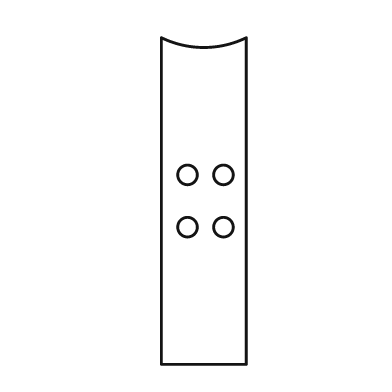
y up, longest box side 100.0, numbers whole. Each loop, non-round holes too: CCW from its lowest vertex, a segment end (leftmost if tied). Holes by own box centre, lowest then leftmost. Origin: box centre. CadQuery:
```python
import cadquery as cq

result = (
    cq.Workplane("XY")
    .moveTo(-13.0, -50.0)
    .lineTo(13.0, -50.0)
    .lineTo(13.0, 50.0)
    .threePointArc((0.0, 47.0), (-13.0, 50.0))
    .close()
    .moveTo(-5.0, -8.0)
    .circle(3.0)
    .moveTo(6.0, -8.0)
    .circle(3.0)
    .moveTo(-5.0, 8.0)
    .circle(3.0)
    .moveTo(6.0, 8.0)
    .circle(3.0)
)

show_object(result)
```